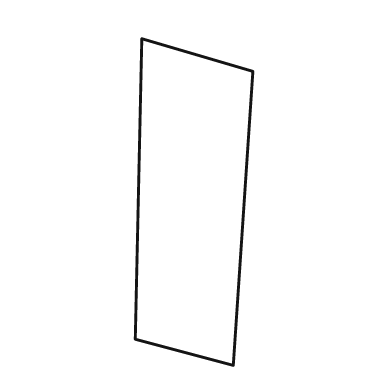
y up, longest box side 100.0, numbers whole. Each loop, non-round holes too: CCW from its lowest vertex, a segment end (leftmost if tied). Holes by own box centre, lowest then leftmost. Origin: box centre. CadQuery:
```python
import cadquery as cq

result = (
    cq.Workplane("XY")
    .moveTo(12.0, -50.0)
    .lineTo(18.0, 40.0)
    .lineTo(-16.0, 50.0)
    .lineTo(-18.0, -42.0)
    .close()
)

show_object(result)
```